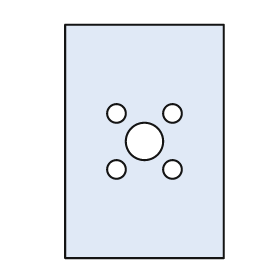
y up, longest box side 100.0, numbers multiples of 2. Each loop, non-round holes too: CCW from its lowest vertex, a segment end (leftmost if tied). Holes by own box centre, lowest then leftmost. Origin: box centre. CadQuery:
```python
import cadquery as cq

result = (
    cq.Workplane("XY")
    .moveTo(-34.0, -50.0)
    .lineTo(34.0, -50.0)
    .lineTo(34.0, 50.0)
    .lineTo(-34.0, 50.0)
    .close()
    .moveTo(-12.0, -12.0)
    .circle(4.0)
    .moveTo(12.0, -12.0)
    .circle(4.0)
    .moveTo(0.0, 0.0)
    .circle(8.0)
    .moveTo(-12.0, 12.0)
    .circle(4.0)
    .moveTo(12.0, 12.0)
    .circle(4.0)
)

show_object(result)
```